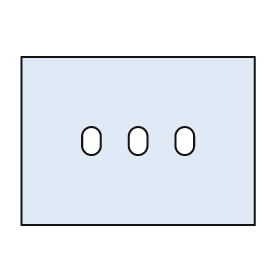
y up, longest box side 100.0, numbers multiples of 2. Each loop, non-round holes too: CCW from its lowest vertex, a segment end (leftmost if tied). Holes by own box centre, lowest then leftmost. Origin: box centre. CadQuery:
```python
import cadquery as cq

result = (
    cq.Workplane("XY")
    .moveTo(-50.0, -36.0)
    .lineTo(50.0, -36.0)
    .lineTo(50.0, 36.0)
    .lineTo(-50.0, 36.0)
    .close()
    .moveTo(-24.0, -2.0)
    .threePointArc((-20.0, -6.0), (-16.0, -2.0))
    .lineTo(-16.0, 2.0)
    .threePointArc((-20.0, 6.0), (-24.0, 2.0))
    .close()
    .moveTo(-4.0, -2.0)
    .threePointArc((0.0, -6.0), (4.0, -2.0))
    .lineTo(4.0, 2.0)
    .threePointArc((0.0, 6.0), (-4.0, 2.0))
    .close()
    .moveTo(16.0, -2.0)
    .threePointArc((20.0, -6.0), (24.0, -2.0))
    .lineTo(24.0, 2.0)
    .threePointArc((20.0, 6.0), (16.0, 2.0))
    .close()
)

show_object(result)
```